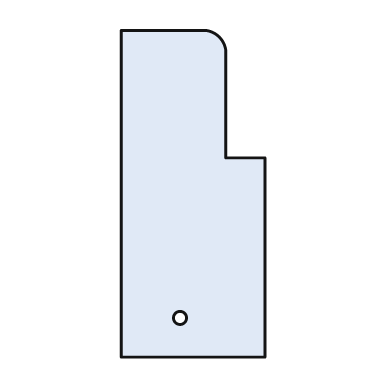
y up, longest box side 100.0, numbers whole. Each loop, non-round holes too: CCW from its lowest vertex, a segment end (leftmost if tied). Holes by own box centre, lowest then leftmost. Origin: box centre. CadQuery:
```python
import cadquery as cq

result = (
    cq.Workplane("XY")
    .moveTo(-22.0, -50.0)
    .lineTo(22.0, -50.0)
    .lineTo(22.0, 11.0)
    .lineTo(10.0, 11.0)
    .lineTo(10.0, 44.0)
    .threePointArc((8.0, 48.0), (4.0, 50.0))
    .lineTo(-22.0, 50.0)
    .close()
    .moveTo(-4.0, -38.0)
    .circle(2.0)
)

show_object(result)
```